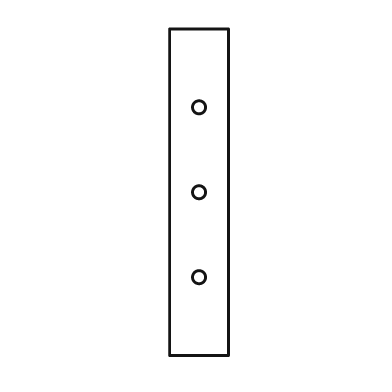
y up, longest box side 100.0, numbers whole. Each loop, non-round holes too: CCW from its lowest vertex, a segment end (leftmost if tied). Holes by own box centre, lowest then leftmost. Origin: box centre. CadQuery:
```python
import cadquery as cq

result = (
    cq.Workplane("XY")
    .moveTo(-9.0, -50.0)
    .lineTo(9.0, -50.0)
    .lineTo(9.0, 50.0)
    .lineTo(-9.0, 50.0)
    .close()
    .moveTo(0.0, -26.0)
    .circle(2.0)
    .moveTo(0.0, 0.0)
    .circle(2.0)
    .moveTo(0.0, 26.0)
    .circle(2.0)
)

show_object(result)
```